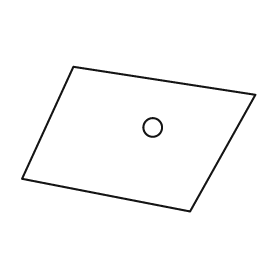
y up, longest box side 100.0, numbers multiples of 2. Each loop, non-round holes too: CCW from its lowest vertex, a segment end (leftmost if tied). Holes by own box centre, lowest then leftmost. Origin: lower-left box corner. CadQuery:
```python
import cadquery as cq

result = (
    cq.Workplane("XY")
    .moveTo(72.0, 0.0)
    .lineTo(100.0, 50.0)
    .lineTo(22.0, 62.0)
    .lineTo(0.0, 14.0)
    .close()
    .moveTo(56.0, 36.0)
    .circle(4.0)
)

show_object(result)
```